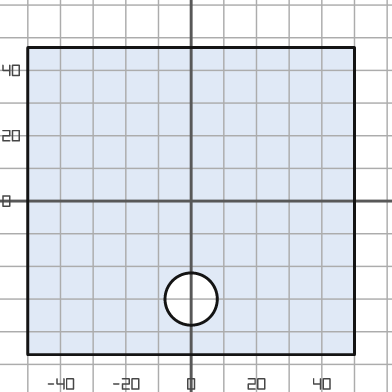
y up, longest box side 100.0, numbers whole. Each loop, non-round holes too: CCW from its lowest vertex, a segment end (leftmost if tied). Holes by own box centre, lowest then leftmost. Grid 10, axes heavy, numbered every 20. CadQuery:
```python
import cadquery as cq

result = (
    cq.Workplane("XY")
    .moveTo(-50.0, -47.0)
    .lineTo(50.0, -47.0)
    .lineTo(50.0, 47.0)
    .lineTo(-50.0, 47.0)
    .close()
    .moveTo(0.0, -30.0)
    .circle(8.0)
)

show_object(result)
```